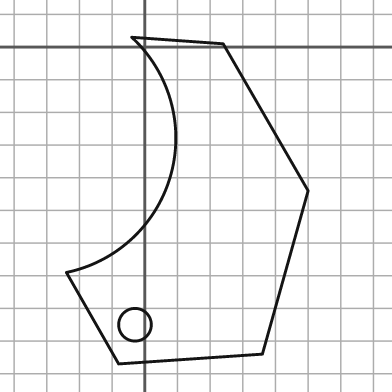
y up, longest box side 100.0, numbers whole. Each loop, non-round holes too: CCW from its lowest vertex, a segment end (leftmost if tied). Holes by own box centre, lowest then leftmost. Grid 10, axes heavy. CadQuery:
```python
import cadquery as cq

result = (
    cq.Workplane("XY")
    .moveTo(-8.0, -97.0)
    .lineTo(36.0, -94.0)
    .lineTo(50.0, -44.0)
    .lineTo(24.0, 1.0)
    .lineTo(-4.0, 3.0)
    .threePointArc((8.0, -39.0), (-24.0, -69.0))
    .close()
    .moveTo(-3.0, -85.0)
    .circle(5.0)
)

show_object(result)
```